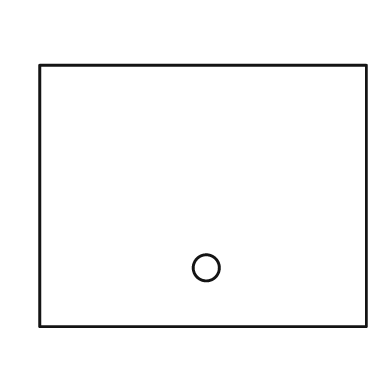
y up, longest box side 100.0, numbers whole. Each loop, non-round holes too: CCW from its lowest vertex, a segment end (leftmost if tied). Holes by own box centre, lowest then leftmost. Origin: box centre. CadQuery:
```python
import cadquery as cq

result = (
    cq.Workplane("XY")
    .moveTo(-50.0, -40.0)
    .lineTo(50.0, -40.0)
    .lineTo(50.0, 40.0)
    .lineTo(-50.0, 40.0)
    .close()
    .moveTo(1.0, -22.0)
    .circle(4.0)
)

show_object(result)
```